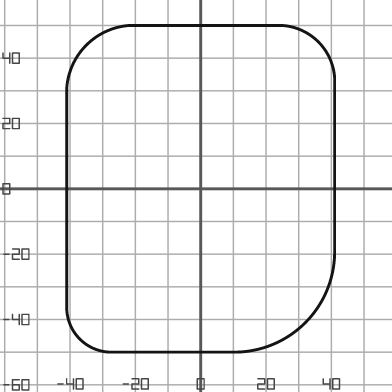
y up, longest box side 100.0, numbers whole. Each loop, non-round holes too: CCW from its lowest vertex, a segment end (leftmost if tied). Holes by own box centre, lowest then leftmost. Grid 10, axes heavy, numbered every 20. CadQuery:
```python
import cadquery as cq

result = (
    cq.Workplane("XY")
    .moveTo(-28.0, -50.0)
    .lineTo(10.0, -50.0)
    .threePointArc((32.0, -41.0), (41.0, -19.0))
    .lineTo(41.0, 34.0)
    .threePointArc((36.0, 45.0), (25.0, 50.0))
    .lineTo(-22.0, 50.0)
    .threePointArc((-35.0, 44.0), (-41.0, 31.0))
    .lineTo(-41.0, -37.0)
    .threePointArc((-37.0, -46.0), (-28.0, -50.0))
    .close()
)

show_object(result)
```